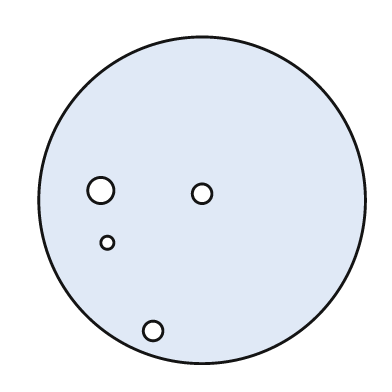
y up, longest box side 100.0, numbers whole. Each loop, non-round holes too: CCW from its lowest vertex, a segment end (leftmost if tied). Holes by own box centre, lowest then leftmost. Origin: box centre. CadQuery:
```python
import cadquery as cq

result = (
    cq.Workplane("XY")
    .moveTo(0.0, 0.0)
    .circle(50.0)
    .moveTo(-15.0, -40.0)
    .circle(3.0)
    .moveTo(-29.0, -13.0)
    .circle(2.0)
    .moveTo(0.0, 2.0)
    .circle(3.0)
    .moveTo(-31.0, 3.0)
    .circle(4.0)
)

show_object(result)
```